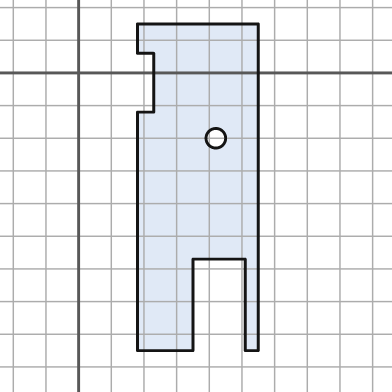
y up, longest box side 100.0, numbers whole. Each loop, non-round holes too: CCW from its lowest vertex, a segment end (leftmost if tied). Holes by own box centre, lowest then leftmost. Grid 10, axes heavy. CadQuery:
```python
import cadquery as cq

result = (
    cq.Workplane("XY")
    .moveTo(18.0, -85.0)
    .lineTo(35.0, -85.0)
    .lineTo(35.0, -57.0)
    .lineTo(51.0, -57.0)
    .lineTo(51.0, -85.0)
    .lineTo(55.0, -85.0)
    .lineTo(55.0, 15.0)
    .lineTo(18.0, 15.0)
    .lineTo(18.0, 6.0)
    .lineTo(23.0, 6.0)
    .lineTo(23.0, -12.0)
    .lineTo(18.0, -12.0)
    .close()
    .moveTo(42.0, -20.0)
    .circle(3.0)
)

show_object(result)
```